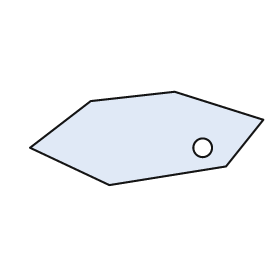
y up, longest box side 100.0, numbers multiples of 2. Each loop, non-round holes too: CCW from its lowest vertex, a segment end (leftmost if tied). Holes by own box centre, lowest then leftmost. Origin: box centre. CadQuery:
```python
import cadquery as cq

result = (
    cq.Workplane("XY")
    .moveTo(-16.0, -20.0)
    .lineTo(34.0, -12.0)
    .lineTo(50.0, 8.0)
    .lineTo(12.0, 20.0)
    .lineTo(-24.0, 16.0)
    .lineTo(-50.0, -4.0)
    .close()
    .moveTo(24.0, -4.0)
    .circle(4.0)
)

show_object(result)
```